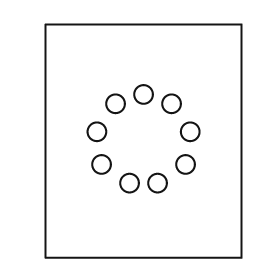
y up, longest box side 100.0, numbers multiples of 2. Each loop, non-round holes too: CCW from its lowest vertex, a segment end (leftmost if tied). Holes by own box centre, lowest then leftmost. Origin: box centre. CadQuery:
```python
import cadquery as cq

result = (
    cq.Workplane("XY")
    .moveTo(-42.0, -50.0)
    .lineTo(42.0, -50.0)
    .lineTo(42.0, 50.0)
    .lineTo(-42.0, 50.0)
    .close()
    .moveTo(-6.0, -18.0)
    .circle(4.0)
    .moveTo(6.0, -18.0)
    .circle(4.0)
    .moveTo(-18.0, -10.0)
    .circle(4.0)
    .moveTo(18.0, -10.0)
    .circle(4.0)
    .moveTo(-20.0, 4.0)
    .circle(4.0)
    .moveTo(20.0, 4.0)
    .circle(4.0)
    .moveTo(-12.0, 16.0)
    .circle(4.0)
    .moveTo(12.0, 16.0)
    .circle(4.0)
    .moveTo(0.0, 20.0)
    .circle(4.0)
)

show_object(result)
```